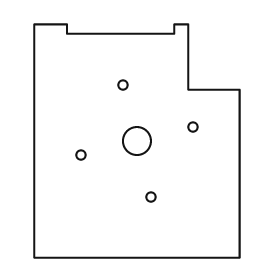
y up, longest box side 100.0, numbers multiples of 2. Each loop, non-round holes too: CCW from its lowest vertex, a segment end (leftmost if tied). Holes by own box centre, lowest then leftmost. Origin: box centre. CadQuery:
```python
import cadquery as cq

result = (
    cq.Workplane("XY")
    .moveTo(-44.0, -50.0)
    .lineTo(44.0, -50.0)
    .lineTo(44.0, 22.0)
    .lineTo(22.0, 22.0)
    .lineTo(22.0, 50.0)
    .lineTo(16.0, 50.0)
    .lineTo(16.0, 46.0)
    .lineTo(-30.0, 46.0)
    .lineTo(-30.0, 50.0)
    .lineTo(-44.0, 50.0)
    .close()
    .moveTo(6.0, -24.0)
    .circle(2.0)
    .moveTo(-24.0, -6.0)
    .circle(2.0)
    .moveTo(0.0, 0.0)
    .circle(6.0)
    .moveTo(24.0, 6.0)
    .circle(2.0)
    .moveTo(-6.0, 24.0)
    .circle(2.0)
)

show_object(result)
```